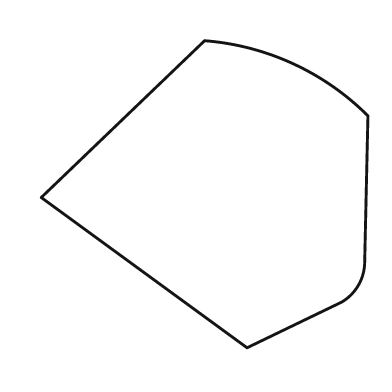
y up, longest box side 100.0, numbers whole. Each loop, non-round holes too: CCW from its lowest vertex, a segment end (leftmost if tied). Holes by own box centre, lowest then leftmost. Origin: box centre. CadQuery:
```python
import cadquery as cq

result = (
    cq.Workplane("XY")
    .moveTo(13.0, -47.0)
    .lineTo(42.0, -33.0)
    .threePointArc((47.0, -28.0), (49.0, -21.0))
    .lineTo(50.0, 24.0)
    .threePointArc((27.0, 40.0), (0.0, 47.0))
    .lineTo(-50.0, -1.0)
    .close()
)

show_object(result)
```